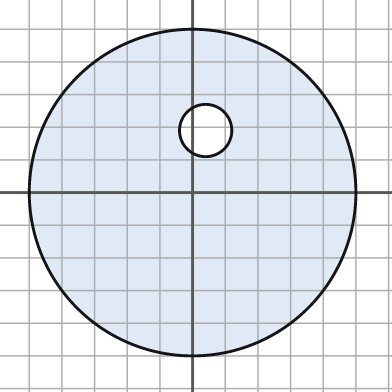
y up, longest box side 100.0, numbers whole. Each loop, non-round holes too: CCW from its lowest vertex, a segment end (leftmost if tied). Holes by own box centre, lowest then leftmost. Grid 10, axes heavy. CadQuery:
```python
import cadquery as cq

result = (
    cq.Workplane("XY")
    .moveTo(0.0, 0.0)
    .circle(50.0)
    .moveTo(4.0, 19.0)
    .circle(8.0)
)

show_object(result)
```